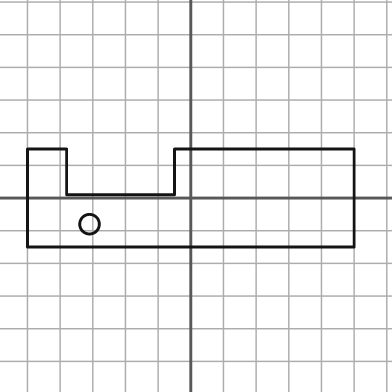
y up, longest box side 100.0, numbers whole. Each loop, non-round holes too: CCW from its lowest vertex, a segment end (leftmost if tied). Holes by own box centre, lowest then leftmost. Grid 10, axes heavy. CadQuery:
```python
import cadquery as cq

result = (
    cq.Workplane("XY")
    .moveTo(-50.0, -15.0)
    .lineTo(50.0, -15.0)
    .lineTo(50.0, 15.0)
    .lineTo(-5.0, 15.0)
    .lineTo(-5.0, 1.0)
    .lineTo(-38.0, 1.0)
    .lineTo(-38.0, 15.0)
    .lineTo(-50.0, 15.0)
    .close()
    .moveTo(-31.0, -8.0)
    .circle(3.0)
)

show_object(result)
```